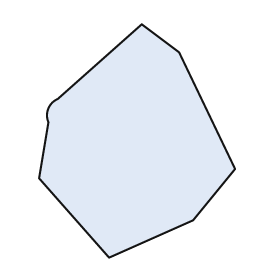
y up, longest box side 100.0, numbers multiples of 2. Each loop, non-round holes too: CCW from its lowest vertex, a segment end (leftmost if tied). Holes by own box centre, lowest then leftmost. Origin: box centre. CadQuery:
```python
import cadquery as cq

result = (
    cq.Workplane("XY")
    .moveTo(-12.0, -50.0)
    .lineTo(24.0, -34.0)
    .lineTo(42.0, -12.0)
    .lineTo(18.0, 38.0)
    .lineTo(2.0, 50.0)
    .lineTo(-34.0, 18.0)
    .threePointArc((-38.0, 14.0), (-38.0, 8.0))
    .lineTo(-42.0, -16.0)
    .close()
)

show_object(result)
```